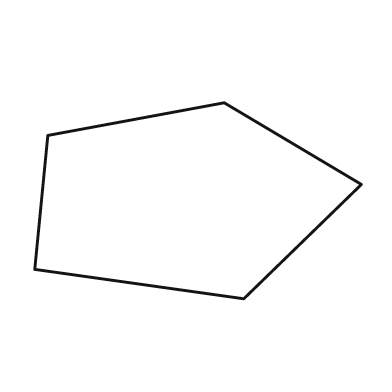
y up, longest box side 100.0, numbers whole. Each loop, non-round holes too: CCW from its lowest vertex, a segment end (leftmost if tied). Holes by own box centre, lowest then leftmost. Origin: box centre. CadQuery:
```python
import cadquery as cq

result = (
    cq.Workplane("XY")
    .moveTo(14.0, -30.0)
    .lineTo(50.0, 5.0)
    .lineTo(8.0, 30.0)
    .lineTo(-46.0, 20.0)
    .lineTo(-50.0, -21.0)
    .close()
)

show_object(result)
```